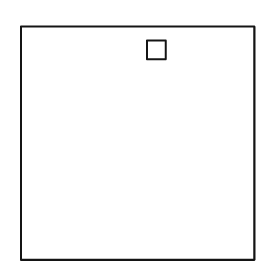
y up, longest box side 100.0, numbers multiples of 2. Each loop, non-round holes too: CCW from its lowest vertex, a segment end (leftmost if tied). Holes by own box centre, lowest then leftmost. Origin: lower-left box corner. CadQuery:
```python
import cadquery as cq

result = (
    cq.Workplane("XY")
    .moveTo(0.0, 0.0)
    .lineTo(100.0, 0.0)
    .lineTo(100.0, 100.0)
    .lineTo(0.0, 100.0)
    .close()
    .moveTo(54.0, 86.0)
    .lineTo(62.0, 86.0)
    .lineTo(62.0, 94.0)
    .lineTo(54.0, 94.0)
    .close()
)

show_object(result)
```